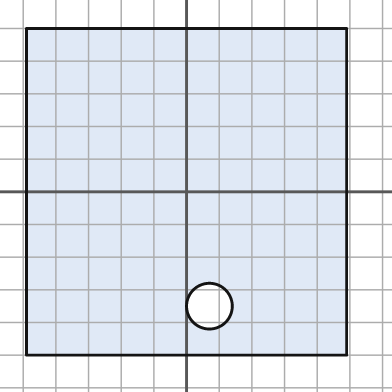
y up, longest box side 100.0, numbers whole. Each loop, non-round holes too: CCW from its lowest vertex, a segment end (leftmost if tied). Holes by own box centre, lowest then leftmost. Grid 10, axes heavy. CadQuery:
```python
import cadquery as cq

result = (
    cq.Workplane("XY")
    .moveTo(-49.0, -50.0)
    .lineTo(49.0, -50.0)
    .lineTo(49.0, 50.0)
    .lineTo(-49.0, 50.0)
    .close()
    .moveTo(7.0, -35.0)
    .circle(7.0)
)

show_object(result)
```